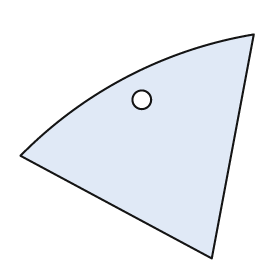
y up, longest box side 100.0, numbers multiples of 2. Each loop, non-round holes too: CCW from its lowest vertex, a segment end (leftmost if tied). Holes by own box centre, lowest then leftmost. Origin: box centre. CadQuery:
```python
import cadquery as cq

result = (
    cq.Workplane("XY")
    .moveTo(32.0, -48.0)
    .lineTo(50.0, 48.0)
    .threePointArc((-4.0, 30.0), (-50.0, -4.0))
    .close()
    .moveTo(2.0, 20.0)
    .circle(4.0)
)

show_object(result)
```